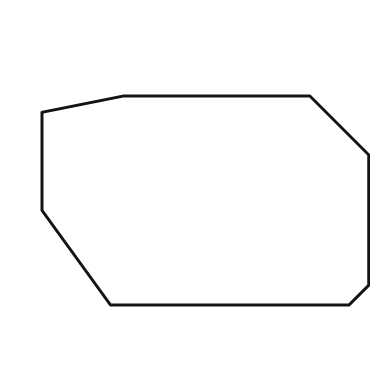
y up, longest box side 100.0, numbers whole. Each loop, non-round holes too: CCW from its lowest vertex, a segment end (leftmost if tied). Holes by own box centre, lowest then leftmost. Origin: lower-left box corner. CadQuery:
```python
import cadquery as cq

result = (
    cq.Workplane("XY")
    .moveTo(21.0, 0.0)
    .lineTo(94.0, 0.0)
    .lineTo(100.0, 6.0)
    .lineTo(100.0, 46.0)
    .lineTo(82.0, 64.0)
    .lineTo(25.0, 64.0)
    .lineTo(0.0, 59.0)
    .lineTo(0.0, 29.0)
    .close()
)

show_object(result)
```